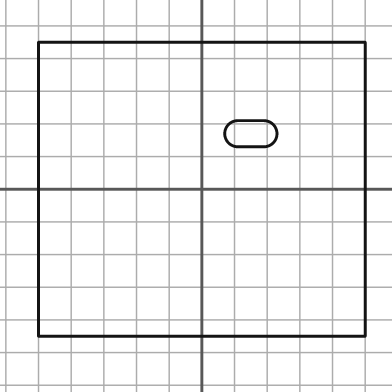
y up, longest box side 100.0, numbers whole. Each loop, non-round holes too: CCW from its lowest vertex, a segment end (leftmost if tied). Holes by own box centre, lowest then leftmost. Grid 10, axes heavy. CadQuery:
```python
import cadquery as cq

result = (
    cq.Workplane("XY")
    .moveTo(-50.0, -45.0)
    .lineTo(50.0, -45.0)
    .lineTo(50.0, 45.0)
    .lineTo(-50.0, 45.0)
    .close()
    .moveTo(11.0, 13.0)
    .lineTo(19.0, 13.0)
    .threePointArc((23.0, 17.0), (19.0, 21.0))
    .lineTo(11.0, 21.0)
    .threePointArc((7.0, 17.0), (11.0, 13.0))
    .close()
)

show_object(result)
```